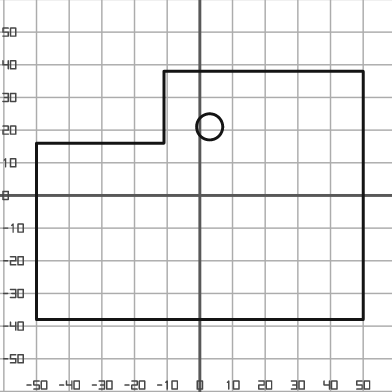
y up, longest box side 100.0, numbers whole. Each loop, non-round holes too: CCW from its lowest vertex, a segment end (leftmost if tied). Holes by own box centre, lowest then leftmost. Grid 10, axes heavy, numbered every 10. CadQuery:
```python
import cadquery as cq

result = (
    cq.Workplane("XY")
    .moveTo(-50.0, -38.0)
    .lineTo(50.0, -38.0)
    .lineTo(50.0, 38.0)
    .lineTo(-11.0, 38.0)
    .lineTo(-11.0, 16.0)
    .lineTo(-50.0, 16.0)
    .close()
    .moveTo(3.0, 21.0)
    .circle(4.0)
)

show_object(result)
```